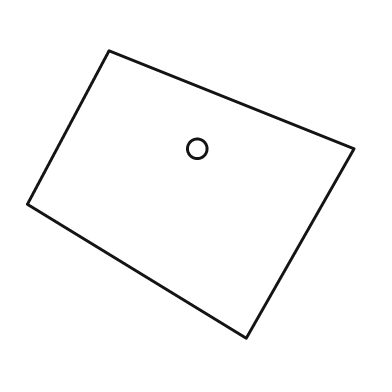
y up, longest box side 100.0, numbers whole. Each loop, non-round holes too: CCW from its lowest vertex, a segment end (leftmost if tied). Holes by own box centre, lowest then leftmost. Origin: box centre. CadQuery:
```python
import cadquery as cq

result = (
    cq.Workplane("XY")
    .moveTo(17.0, -44.0)
    .lineTo(50.0, 14.0)
    .lineTo(-25.0, 44.0)
    .lineTo(-50.0, -3.0)
    .close()
    .moveTo(2.0, 14.0)
    .circle(3.0)
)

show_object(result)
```